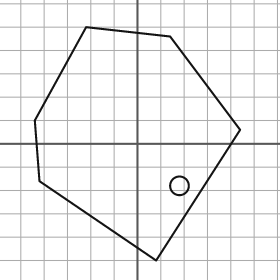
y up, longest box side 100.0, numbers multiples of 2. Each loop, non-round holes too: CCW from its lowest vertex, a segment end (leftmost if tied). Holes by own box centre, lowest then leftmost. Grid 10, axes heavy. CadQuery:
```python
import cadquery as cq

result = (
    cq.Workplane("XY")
    .moveTo(8.0, -50.0)
    .lineTo(44.0, 6.0)
    .lineTo(14.0, 46.0)
    .lineTo(-22.0, 50.0)
    .lineTo(-44.0, 10.0)
    .lineTo(-42.0, -16.0)
    .close()
    .moveTo(18.0, -18.0)
    .circle(4.0)
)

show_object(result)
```